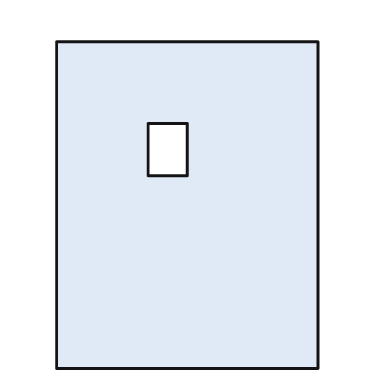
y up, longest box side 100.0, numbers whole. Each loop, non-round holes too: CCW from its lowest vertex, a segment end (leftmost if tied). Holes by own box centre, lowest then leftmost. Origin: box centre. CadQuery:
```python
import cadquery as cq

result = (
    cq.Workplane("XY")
    .moveTo(-40.0, -50.0)
    .lineTo(40.0, -50.0)
    .lineTo(40.0, 50.0)
    .lineTo(-40.0, 50.0)
    .close()
    .moveTo(-12.0, 9.0)
    .lineTo(0.0, 9.0)
    .lineTo(0.0, 25.0)
    .lineTo(-12.0, 25.0)
    .close()
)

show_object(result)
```